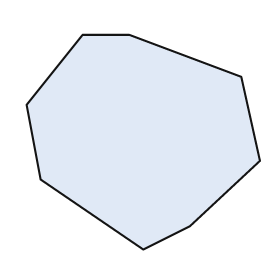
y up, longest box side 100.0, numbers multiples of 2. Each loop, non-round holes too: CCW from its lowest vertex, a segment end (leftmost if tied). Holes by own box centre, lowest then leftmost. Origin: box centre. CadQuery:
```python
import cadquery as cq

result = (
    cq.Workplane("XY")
    .moveTo(0.0, -46.0)
    .lineTo(20.0, -36.0)
    .lineTo(50.0, -8.0)
    .lineTo(42.0, 28.0)
    .lineTo(-6.0, 46.0)
    .lineTo(-26.0, 46.0)
    .lineTo(-50.0, 16.0)
    .lineTo(-44.0, -16.0)
    .close()
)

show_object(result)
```